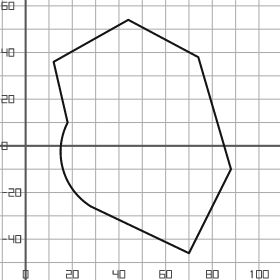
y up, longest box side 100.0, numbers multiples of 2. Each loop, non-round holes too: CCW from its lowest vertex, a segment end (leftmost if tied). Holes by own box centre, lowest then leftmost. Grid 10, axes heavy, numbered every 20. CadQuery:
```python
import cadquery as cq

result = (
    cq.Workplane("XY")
    .moveTo(70.0, -46.0)
    .lineTo(88.0, -10.0)
    .lineTo(74.0, 38.0)
    .lineTo(44.0, 54.0)
    .lineTo(12.0, 36.0)
    .lineTo(18.0, 10.0)
    .threePointArc((16.0, -10.0), (28.0, -26.0))
    .close()
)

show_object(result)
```